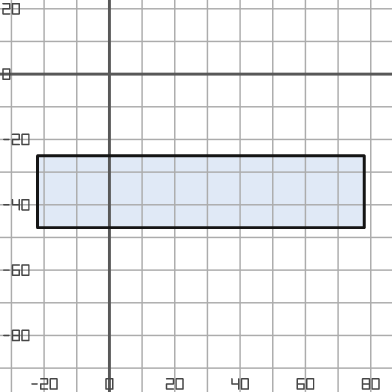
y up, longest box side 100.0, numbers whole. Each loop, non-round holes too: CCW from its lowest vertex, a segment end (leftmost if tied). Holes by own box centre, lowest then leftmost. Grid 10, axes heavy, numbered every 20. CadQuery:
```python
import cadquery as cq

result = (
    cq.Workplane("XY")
    .moveTo(-22.0, -47.0)
    .lineTo(78.0, -47.0)
    .lineTo(78.0, -25.0)
    .lineTo(-22.0, -25.0)
    .close()
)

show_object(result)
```